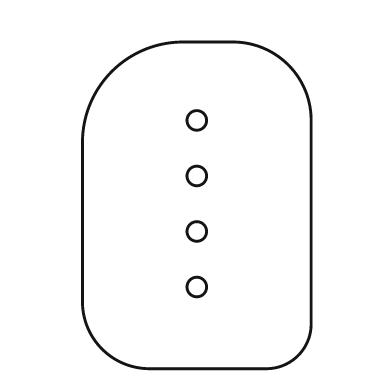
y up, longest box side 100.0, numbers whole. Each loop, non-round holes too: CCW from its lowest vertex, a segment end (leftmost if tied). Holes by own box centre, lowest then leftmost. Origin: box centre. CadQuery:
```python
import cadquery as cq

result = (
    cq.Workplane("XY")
    .moveTo(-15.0, -50.0)
    .lineTo(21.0, -50.0)
    .threePointArc((31.0, -46.0), (35.0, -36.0))
    .lineTo(35.0, 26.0)
    .threePointArc((28.0, 43.0), (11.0, 50.0))
    .lineTo(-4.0, 50.0)
    .threePointArc((-26.0, 41.0), (-35.0, 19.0))
    .lineTo(-35.0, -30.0)
    .threePointArc((-29.0, -44.0), (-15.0, -50.0))
    .close()
    .moveTo(0.0, -25.0)
    .circle(3.0)
    .moveTo(0.0, -8.0)
    .circle(3.0)
    .moveTo(0.0, 9.0)
    .circle(3.0)
    .moveTo(0.0, 26.0)
    .circle(3.0)
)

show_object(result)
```